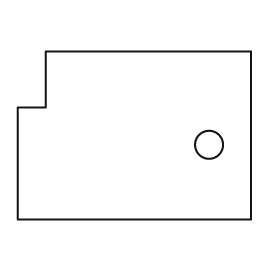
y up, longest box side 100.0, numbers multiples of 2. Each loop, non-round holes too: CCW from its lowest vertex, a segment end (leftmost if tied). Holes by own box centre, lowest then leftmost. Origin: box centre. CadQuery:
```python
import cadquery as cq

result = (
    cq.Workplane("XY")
    .moveTo(-50.0, -36.0)
    .lineTo(50.0, -36.0)
    .lineTo(50.0, 36.0)
    .lineTo(-38.0, 36.0)
    .lineTo(-38.0, 12.0)
    .lineTo(-50.0, 12.0)
    .close()
    .moveTo(32.0, -4.0)
    .circle(6.0)
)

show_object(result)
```